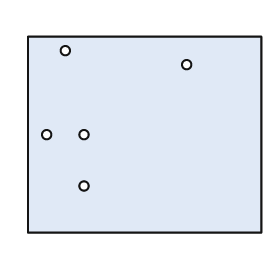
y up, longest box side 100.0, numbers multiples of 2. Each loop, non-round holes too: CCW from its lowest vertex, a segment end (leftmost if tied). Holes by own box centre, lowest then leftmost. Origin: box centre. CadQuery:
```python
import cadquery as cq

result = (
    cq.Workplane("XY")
    .moveTo(-50.0, -42.0)
    .lineTo(50.0, -42.0)
    .lineTo(50.0, 42.0)
    .lineTo(-50.0, 42.0)
    .close()
    .moveTo(-26.0, -22.0)
    .circle(2.0)
    .moveTo(-42.0, 0.0)
    .circle(2.0)
    .moveTo(-26.0, 0.0)
    .circle(2.0)
    .moveTo(18.0, 30.0)
    .circle(2.0)
    .moveTo(-34.0, 36.0)
    .circle(2.0)
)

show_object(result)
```